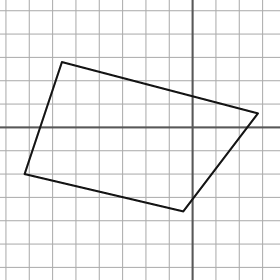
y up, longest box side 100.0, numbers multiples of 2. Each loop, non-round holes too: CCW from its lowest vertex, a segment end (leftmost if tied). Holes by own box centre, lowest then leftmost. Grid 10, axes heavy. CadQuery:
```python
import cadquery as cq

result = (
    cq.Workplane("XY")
    .moveTo(-4.0, -36.0)
    .lineTo(28.0, 6.0)
    .lineTo(-56.0, 28.0)
    .lineTo(-72.0, -20.0)
    .close()
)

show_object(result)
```